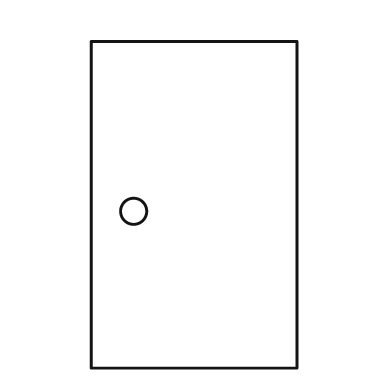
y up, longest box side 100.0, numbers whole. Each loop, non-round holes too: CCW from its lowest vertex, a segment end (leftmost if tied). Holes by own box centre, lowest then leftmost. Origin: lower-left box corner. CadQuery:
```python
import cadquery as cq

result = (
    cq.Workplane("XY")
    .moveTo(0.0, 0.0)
    .lineTo(63.0, 0.0)
    .lineTo(63.0, 100.0)
    .lineTo(0.0, 100.0)
    .close()
    .moveTo(13.0, 48.0)
    .circle(4.0)
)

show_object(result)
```